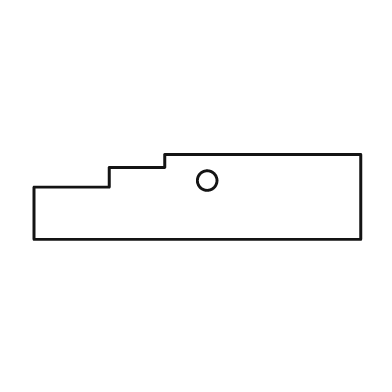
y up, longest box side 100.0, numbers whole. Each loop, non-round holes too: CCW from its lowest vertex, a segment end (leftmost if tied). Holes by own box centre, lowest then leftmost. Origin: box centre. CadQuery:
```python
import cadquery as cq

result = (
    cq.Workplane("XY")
    .moveTo(-50.0, -13.0)
    .lineTo(50.0, -13.0)
    .lineTo(50.0, 13.0)
    .lineTo(-10.0, 13.0)
    .lineTo(-10.0, 9.0)
    .lineTo(-27.0, 9.0)
    .lineTo(-27.0, 3.0)
    .lineTo(-50.0, 3.0)
    .close()
    .moveTo(3.0, 5.0)
    .circle(3.0)
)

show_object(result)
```